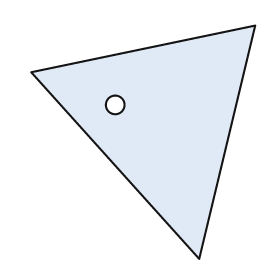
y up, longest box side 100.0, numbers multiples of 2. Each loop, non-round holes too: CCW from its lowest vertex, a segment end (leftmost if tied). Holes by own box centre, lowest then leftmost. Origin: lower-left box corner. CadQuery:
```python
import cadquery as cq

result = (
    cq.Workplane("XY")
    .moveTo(72.0, 0.0)
    .lineTo(96.0, 100.0)
    .lineTo(0.0, 80.0)
    .close()
    .moveTo(36.0, 66.0)
    .circle(4.0)
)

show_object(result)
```